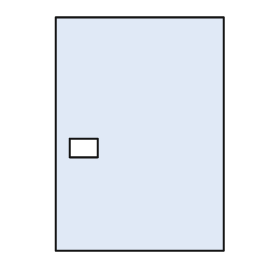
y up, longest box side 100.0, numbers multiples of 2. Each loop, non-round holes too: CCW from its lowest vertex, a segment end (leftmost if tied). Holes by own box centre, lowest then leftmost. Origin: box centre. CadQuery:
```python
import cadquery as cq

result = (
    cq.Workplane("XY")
    .moveTo(-36.0, -50.0)
    .lineTo(36.0, -50.0)
    .lineTo(36.0, 50.0)
    .lineTo(-36.0, 50.0)
    .close()
    .moveTo(-30.0, -10.0)
    .lineTo(-18.0, -10.0)
    .lineTo(-18.0, -2.0)
    .lineTo(-30.0, -2.0)
    .close()
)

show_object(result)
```